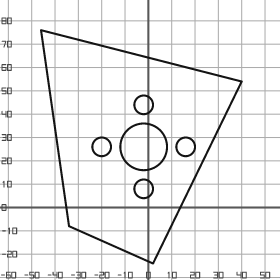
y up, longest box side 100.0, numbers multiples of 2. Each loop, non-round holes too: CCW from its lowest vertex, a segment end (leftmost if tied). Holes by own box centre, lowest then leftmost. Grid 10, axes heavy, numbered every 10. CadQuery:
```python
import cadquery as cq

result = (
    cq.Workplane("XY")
    .moveTo(2.0, -24.0)
    .lineTo(40.0, 54.0)
    .lineTo(-46.0, 76.0)
    .lineTo(-34.0, -8.0)
    .close()
    .moveTo(-2.0, 8.0)
    .circle(4.0)
    .moveTo(-20.0, 26.0)
    .circle(4.0)
    .moveTo(-2.0, 26.0)
    .circle(10.0)
    .moveTo(16.0, 26.0)
    .circle(4.0)
    .moveTo(-2.0, 44.0)
    .circle(4.0)
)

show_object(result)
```